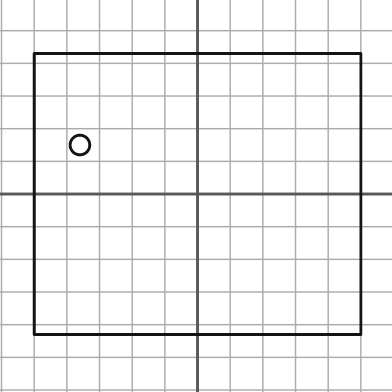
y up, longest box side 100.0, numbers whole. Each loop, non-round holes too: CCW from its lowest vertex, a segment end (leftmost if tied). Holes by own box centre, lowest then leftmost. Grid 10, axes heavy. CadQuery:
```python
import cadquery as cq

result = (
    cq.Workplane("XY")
    .moveTo(-50.0, -43.0)
    .lineTo(50.0, -43.0)
    .lineTo(50.0, 43.0)
    .lineTo(-50.0, 43.0)
    .close()
    .moveTo(-36.0, 15.0)
    .circle(3.0)
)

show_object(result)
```